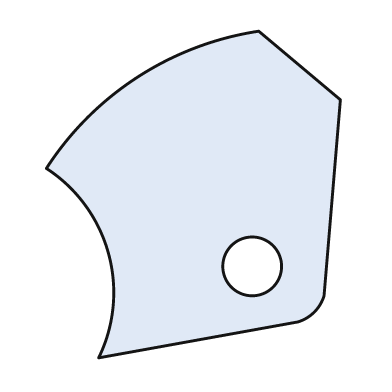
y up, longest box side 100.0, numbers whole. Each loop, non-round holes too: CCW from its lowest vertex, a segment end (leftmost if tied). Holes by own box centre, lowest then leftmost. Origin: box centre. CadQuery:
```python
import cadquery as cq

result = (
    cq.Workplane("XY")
    .moveTo(-29.0, -50.0)
    .lineTo(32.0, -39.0)
    .threePointArc((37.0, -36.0), (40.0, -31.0))
    .lineTo(45.0, 29.0)
    .lineTo(20.0, 50.0)
    .threePointArc((-17.0, 36.0), (-45.0, 8.0))
    .threePointArc((-26.0, -18.0), (-29.0, -50.0))
    .close()
    .moveTo(18.0, -22.0)
    .circle(9.0)
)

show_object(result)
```